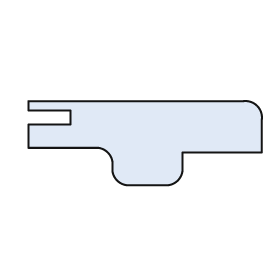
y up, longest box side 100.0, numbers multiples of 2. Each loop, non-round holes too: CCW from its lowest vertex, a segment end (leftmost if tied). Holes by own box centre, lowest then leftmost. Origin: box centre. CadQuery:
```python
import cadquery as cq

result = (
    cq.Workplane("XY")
    .moveTo(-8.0, -18.0)
    .lineTo(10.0, -18.0)
    .threePointArc((14.0, -16.0), (16.0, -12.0))
    .lineTo(16.0, -4.0)
    .lineTo(50.0, -4.0)
    .lineTo(50.0, 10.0)
    .threePointArc((48.0, 16.0), (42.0, 18.0))
    .lineTo(-50.0, 18.0)
    .lineTo(-50.0, 14.0)
    .lineTo(-32.0, 14.0)
    .lineTo(-32.0, 8.0)
    .lineTo(-50.0, 8.0)
    .lineTo(-50.0, -2.0)
    .lineTo(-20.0, -2.0)
    .threePointArc((-16.0, -4.0), (-14.0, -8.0))
    .lineTo(-14.0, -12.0)
    .threePointArc((-12.0, -16.0), (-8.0, -18.0))
    .close()
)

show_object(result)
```